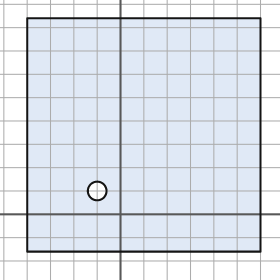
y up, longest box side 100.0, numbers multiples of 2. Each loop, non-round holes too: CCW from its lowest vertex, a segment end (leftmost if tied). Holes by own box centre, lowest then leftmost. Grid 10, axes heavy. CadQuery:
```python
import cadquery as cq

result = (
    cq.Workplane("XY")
    .moveTo(-40.0, -16.0)
    .lineTo(60.0, -16.0)
    .lineTo(60.0, 84.0)
    .lineTo(-40.0, 84.0)
    .close()
    .moveTo(-10.0, 10.0)
    .circle(4.0)
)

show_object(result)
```